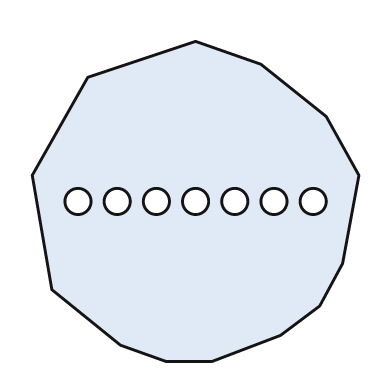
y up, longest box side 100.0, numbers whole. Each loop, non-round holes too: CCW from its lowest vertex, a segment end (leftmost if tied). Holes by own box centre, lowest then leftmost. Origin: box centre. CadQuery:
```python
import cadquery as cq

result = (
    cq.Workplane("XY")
    .moveTo(-9.0, -49.0)
    .lineTo(5.0, -49.0)
    .lineTo(26.0, -41.0)
    .lineTo(38.0, -32.0)
    .lineTo(45.0, -19.0)
    .lineTo(50.0, 8.0)
    .lineTo(40.0, 26.0)
    .lineTo(20.0, 42.0)
    .lineTo(0.0, 49.0)
    .lineTo(-33.0, 38.0)
    .lineTo(-50.0, 8.0)
    .lineTo(-44.0, -27.0)
    .lineTo(-23.0, -44.0)
    .close()
    .moveTo(-36.0, 0.0)
    .circle(4.0)
    .moveTo(-24.0, 0.0)
    .circle(4.0)
    .moveTo(-12.0, 0.0)
    .circle(4.0)
    .moveTo(0.0, 0.0)
    .circle(4.0)
    .moveTo(12.0, 0.0)
    .circle(4.0)
    .moveTo(24.0, 0.0)
    .circle(4.0)
    .moveTo(36.0, 0.0)
    .circle(4.0)
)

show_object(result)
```